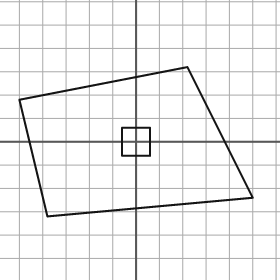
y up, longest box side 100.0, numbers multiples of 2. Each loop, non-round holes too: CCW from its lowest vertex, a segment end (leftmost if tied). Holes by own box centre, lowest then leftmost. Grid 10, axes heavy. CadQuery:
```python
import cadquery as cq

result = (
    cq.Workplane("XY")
    .moveTo(-38.0, -32.0)
    .lineTo(50.0, -24.0)
    .lineTo(22.0, 32.0)
    .lineTo(-50.0, 18.0)
    .close()
    .moveTo(-6.0, -6.0)
    .lineTo(6.0, -6.0)
    .lineTo(6.0, 6.0)
    .lineTo(-6.0, 6.0)
    .close()
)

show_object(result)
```